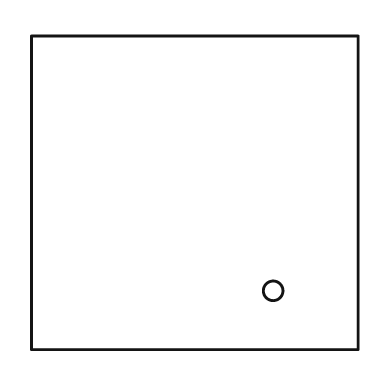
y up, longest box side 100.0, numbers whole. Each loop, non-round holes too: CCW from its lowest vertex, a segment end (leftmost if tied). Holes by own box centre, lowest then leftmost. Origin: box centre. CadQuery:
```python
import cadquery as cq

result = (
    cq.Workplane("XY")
    .moveTo(-50.0, -48.0)
    .lineTo(50.0, -48.0)
    .lineTo(50.0, 48.0)
    .lineTo(-50.0, 48.0)
    .close()
    .moveTo(24.0, -30.0)
    .circle(3.0)
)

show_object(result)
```